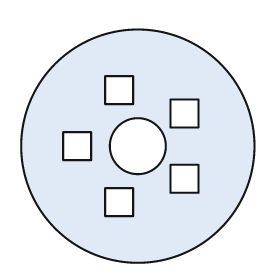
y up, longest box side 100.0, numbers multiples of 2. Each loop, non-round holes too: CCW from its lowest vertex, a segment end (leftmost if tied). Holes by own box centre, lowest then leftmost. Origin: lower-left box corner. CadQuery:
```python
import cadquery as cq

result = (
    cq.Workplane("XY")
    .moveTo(50.0, 50.0)
    .circle(50.0)
    .moveTo(36.0, 20.0)
    .lineTo(48.0, 20.0)
    .lineTo(48.0, 32.0)
    .lineTo(36.0, 32.0)
    .close()
    .moveTo(64.0, 30.0)
    .lineTo(76.0, 30.0)
    .lineTo(76.0, 42.0)
    .lineTo(64.0, 42.0)
    .close()
    .moveTo(18.0, 44.0)
    .lineTo(30.0, 44.0)
    .lineTo(30.0, 56.0)
    .lineTo(18.0, 56.0)
    .close()
    .moveTo(50.0, 50.0)
    .circle(12.0)
    .moveTo(64.0, 58.0)
    .lineTo(76.0, 58.0)
    .lineTo(76.0, 70.0)
    .lineTo(64.0, 70.0)
    .close()
    .moveTo(36.0, 68.0)
    .lineTo(48.0, 68.0)
    .lineTo(48.0, 80.0)
    .lineTo(36.0, 80.0)
    .close()
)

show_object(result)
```